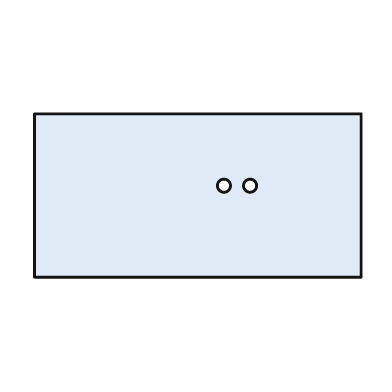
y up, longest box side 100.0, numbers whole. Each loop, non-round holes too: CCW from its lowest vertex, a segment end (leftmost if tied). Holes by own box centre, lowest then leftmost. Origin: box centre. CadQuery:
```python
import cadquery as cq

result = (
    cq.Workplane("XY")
    .moveTo(-50.0, -25.0)
    .lineTo(50.0, -25.0)
    .lineTo(50.0, 25.0)
    .lineTo(-50.0, 25.0)
    .close()
    .moveTo(8.0, 3.0)
    .circle(2.0)
    .moveTo(16.0, 3.0)
    .circle(2.0)
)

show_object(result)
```